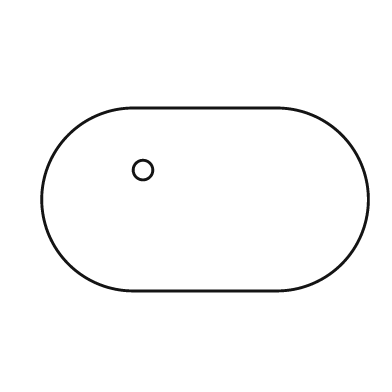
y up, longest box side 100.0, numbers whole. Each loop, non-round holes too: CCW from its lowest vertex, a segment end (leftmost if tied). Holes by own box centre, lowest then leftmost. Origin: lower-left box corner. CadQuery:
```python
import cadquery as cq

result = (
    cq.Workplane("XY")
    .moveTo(28.0, 0.0)
    .lineTo(72.0, 0.0)
    .threePointArc((100.0, 28.0), (72.0, 56.0))
    .lineTo(28.0, 56.0)
    .threePointArc((0.0, 28.0), (28.0, 0.0))
    .close()
    .moveTo(31.0, 37.0)
    .circle(3.0)
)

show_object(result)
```